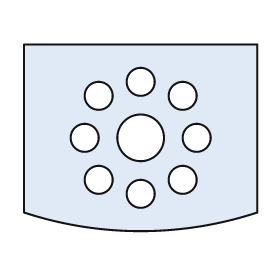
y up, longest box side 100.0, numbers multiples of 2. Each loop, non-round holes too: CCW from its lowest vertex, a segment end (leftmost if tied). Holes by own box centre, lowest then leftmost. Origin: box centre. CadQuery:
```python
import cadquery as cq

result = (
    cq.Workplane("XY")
    .moveTo(-50.0, -32.0)
    .threePointArc((0.0, -40.0), (50.0, -32.0))
    .lineTo(50.0, 40.0)
    .lineTo(-50.0, 40.0)
    .close()
    .moveTo(0.0, -24.0)
    .circle(6.0)
    .moveTo(-18.0, -18.0)
    .circle(6.0)
    .moveTo(18.0, -18.0)
    .circle(6.0)
    .moveTo(-24.0, 0.0)
    .circle(6.0)
    .moveTo(0.0, 0.0)
    .circle(10.0)
    .moveTo(24.0, 0.0)
    .circle(6.0)
    .moveTo(-18.0, 18.0)
    .circle(6.0)
    .moveTo(18.0, 18.0)
    .circle(6.0)
    .moveTo(0.0, 24.0)
    .circle(6.0)
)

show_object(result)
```